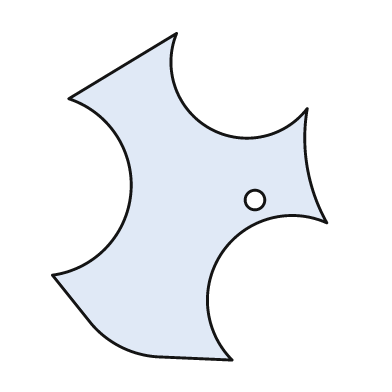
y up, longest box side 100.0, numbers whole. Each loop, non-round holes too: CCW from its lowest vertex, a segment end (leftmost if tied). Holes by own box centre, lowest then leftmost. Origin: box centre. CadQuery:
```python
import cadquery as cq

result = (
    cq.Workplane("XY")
    .moveTo(13.0, -50.0)
    .threePointArc((10.0, -17.0), (42.0, -8.0))
    .threePointArc((36.0, 9.0), (36.0, 27.0))
    .threePointArc((6.0, 21.0), (-4.0, 50.0))
    .lineTo(-37.0, 30.0)
    .threePointArc((-18.0, 1.0), (-42.0, -24.0))
    .lineTo(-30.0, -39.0)
    .threePointArc((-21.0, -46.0), (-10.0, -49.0))
    .close()
    .moveTo(20.0, -1.0)
    .circle(3.0)
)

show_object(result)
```